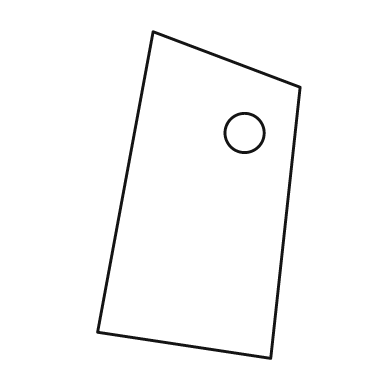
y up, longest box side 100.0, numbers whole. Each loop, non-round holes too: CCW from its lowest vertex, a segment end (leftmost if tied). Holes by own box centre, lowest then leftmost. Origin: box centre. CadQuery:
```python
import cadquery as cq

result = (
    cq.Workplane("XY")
    .moveTo(22.0, -50.0)
    .lineTo(31.0, 33.0)
    .lineTo(-14.0, 50.0)
    .lineTo(-31.0, -42.0)
    .close()
    .moveTo(14.0, 19.0)
    .circle(6.0)
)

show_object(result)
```